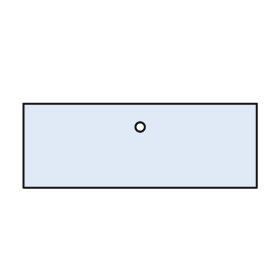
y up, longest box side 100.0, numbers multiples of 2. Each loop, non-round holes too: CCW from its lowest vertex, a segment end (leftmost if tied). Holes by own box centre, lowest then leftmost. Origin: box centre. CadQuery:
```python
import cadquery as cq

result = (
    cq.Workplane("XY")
    .moveTo(-50.0, -18.0)
    .lineTo(50.0, -18.0)
    .lineTo(50.0, 18.0)
    .lineTo(-50.0, 18.0)
    .close()
    .moveTo(0.0, 8.0)
    .circle(2.0)
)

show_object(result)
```